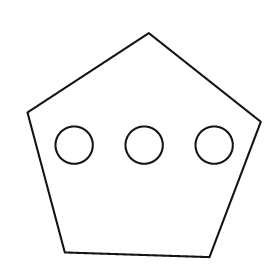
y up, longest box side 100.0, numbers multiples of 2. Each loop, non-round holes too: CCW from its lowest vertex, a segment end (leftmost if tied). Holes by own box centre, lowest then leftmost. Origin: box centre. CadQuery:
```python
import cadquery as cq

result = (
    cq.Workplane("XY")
    .moveTo(28.0, -48.0)
    .lineTo(50.0, 10.0)
    .lineTo(2.0, 48.0)
    .lineTo(-50.0, 14.0)
    .lineTo(-34.0, -46.0)
    .close()
    .moveTo(-30.0, 0.0)
    .circle(8.0)
    .moveTo(0.0, 0.0)
    .circle(8.0)
    .moveTo(30.0, 0.0)
    .circle(8.0)
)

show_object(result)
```